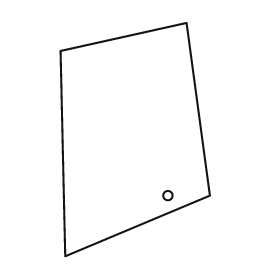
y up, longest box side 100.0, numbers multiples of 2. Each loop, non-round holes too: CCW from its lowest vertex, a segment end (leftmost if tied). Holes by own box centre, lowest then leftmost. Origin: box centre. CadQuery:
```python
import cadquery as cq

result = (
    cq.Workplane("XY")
    .moveTo(-30.0, -50.0)
    .lineTo(32.0, -24.0)
    .lineTo(22.0, 50.0)
    .lineTo(-32.0, 38.0)
    .close()
    .moveTo(14.0, -24.0)
    .circle(2.0)
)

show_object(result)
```